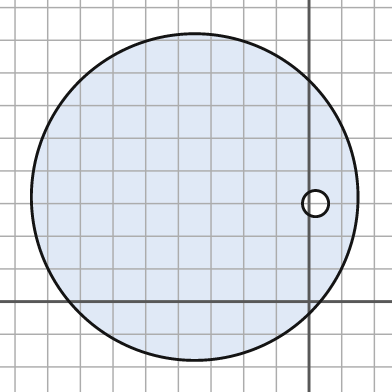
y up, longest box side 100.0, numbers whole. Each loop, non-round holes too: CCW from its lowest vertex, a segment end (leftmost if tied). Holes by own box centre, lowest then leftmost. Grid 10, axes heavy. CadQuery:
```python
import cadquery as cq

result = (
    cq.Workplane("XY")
    .moveTo(-35.0, 32.0)
    .circle(50.0)
    .moveTo(2.0, 30.0)
    .circle(4.0)
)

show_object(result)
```